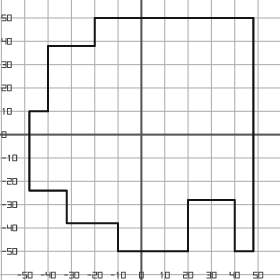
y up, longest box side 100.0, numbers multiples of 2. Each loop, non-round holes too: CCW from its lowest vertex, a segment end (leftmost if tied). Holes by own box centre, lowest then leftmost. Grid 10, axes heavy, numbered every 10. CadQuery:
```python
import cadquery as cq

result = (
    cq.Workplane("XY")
    .moveTo(-10.0, -50.0)
    .lineTo(20.0, -50.0)
    .lineTo(20.0, -28.0)
    .lineTo(40.0, -28.0)
    .lineTo(40.0, -50.0)
    .lineTo(48.0, -50.0)
    .lineTo(48.0, 50.0)
    .lineTo(-20.0, 50.0)
    .lineTo(-20.0, 38.0)
    .lineTo(-40.0, 38.0)
    .lineTo(-40.0, 10.0)
    .lineTo(-48.0, 10.0)
    .lineTo(-48.0, -24.0)
    .lineTo(-32.0, -24.0)
    .lineTo(-32.0, -38.0)
    .lineTo(-10.0, -38.0)
    .close()
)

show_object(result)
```